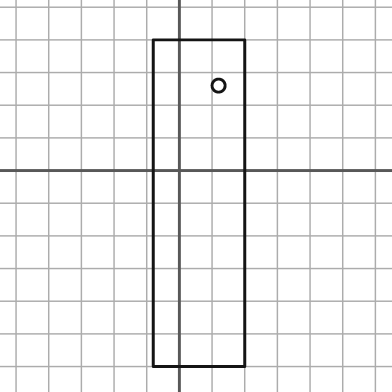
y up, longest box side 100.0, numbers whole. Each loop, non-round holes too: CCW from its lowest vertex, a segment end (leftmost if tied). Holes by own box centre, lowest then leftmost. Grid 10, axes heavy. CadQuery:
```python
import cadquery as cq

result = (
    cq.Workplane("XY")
    .moveTo(-8.0, -60.0)
    .lineTo(20.0, -60.0)
    .lineTo(20.0, 40.0)
    .lineTo(-8.0, 40.0)
    .close()
    .moveTo(12.0, 26.0)
    .circle(2.0)
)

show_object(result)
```